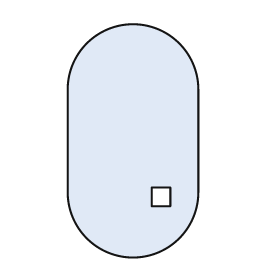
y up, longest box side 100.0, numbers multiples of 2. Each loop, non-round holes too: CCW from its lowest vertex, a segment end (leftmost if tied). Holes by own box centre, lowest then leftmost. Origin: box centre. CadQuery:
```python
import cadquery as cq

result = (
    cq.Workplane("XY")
    .moveTo(-28.0, -22.0)
    .threePointArc((0.0, -50.0), (28.0, -22.0))
    .lineTo(28.0, 22.0)
    .threePointArc((0.0, 50.0), (-28.0, 22.0))
    .close()
    .moveTo(8.0, -28.0)
    .lineTo(16.0, -28.0)
    .lineTo(16.0, -20.0)
    .lineTo(8.0, -20.0)
    .close()
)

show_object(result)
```